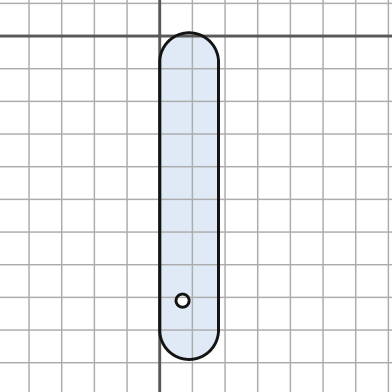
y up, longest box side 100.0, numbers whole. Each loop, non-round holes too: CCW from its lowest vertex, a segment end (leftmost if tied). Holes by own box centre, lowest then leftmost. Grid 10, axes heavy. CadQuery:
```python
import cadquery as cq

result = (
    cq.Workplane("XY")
    .moveTo(0.0, -90.0)
    .threePointArc((9.0, -99.0), (18.0, -90.0))
    .lineTo(18.0, -8.0)
    .threePointArc((9.0, 1.0), (0.0, -8.0))
    .close()
    .moveTo(7.0, -81.0)
    .circle(2.0)
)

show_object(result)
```